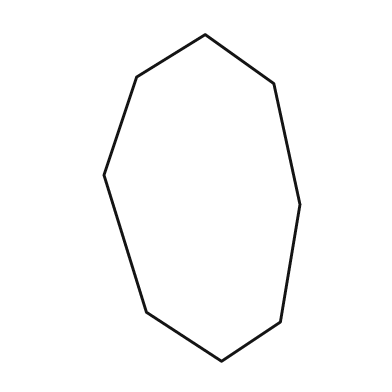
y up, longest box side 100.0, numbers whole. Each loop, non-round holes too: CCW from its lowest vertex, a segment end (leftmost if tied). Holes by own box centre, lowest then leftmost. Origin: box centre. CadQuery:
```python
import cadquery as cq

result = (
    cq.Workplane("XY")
    .moveTo(6.0, -50.0)
    .lineTo(24.0, -38.0)
    .lineTo(30.0, -2.0)
    .lineTo(22.0, 35.0)
    .lineTo(1.0, 50.0)
    .lineTo(-20.0, 37.0)
    .lineTo(-30.0, 7.0)
    .lineTo(-17.0, -35.0)
    .close()
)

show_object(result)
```